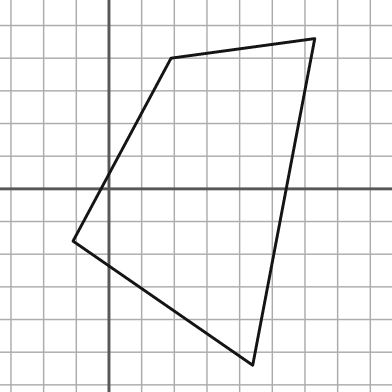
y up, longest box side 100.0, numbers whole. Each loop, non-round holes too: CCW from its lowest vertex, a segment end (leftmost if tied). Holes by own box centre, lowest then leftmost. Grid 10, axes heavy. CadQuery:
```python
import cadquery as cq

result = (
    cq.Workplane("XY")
    .moveTo(44.0, -54.0)
    .lineTo(63.0, 46.0)
    .lineTo(19.0, 40.0)
    .lineTo(-11.0, -16.0)
    .close()
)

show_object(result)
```